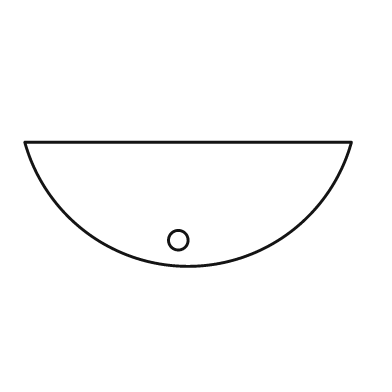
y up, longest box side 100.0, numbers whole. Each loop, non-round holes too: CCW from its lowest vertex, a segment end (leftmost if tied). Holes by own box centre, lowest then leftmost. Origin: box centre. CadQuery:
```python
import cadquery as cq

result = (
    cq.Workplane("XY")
    .moveTo(-50.0, 19.0)
    .threePointArc((0.0, -19.0), (50.0, 19.0))
    .close()
    .moveTo(-3.0, -11.0)
    .circle(3.0)
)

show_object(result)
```